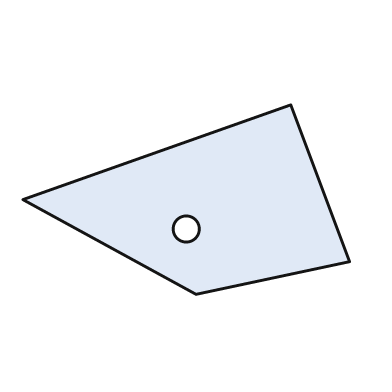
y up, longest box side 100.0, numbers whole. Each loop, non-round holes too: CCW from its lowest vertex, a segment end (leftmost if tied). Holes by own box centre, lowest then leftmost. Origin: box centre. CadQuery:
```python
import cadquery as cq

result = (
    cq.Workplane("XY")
    .moveTo(3.0, -29.0)
    .lineTo(50.0, -19.0)
    .lineTo(32.0, 29.0)
    .lineTo(-50.0, 0.0)
    .close()
    .moveTo(0.0, -9.0)
    .circle(4.0)
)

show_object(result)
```